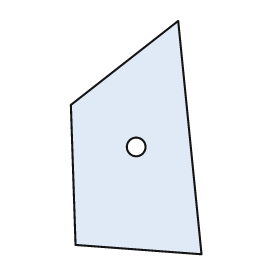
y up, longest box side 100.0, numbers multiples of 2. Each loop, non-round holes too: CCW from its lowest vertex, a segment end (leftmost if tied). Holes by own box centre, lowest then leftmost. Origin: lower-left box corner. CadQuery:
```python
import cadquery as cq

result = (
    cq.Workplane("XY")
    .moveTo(56.0, 0.0)
    .lineTo(46.0, 100.0)
    .lineTo(0.0, 64.0)
    .lineTo(2.0, 4.0)
    .close()
    .moveTo(28.0, 46.0)
    .circle(4.0)
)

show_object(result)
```